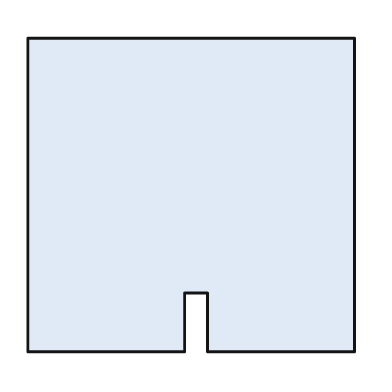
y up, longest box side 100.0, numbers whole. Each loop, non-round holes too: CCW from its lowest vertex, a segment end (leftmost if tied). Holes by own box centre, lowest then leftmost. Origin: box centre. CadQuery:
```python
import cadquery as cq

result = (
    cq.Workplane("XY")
    .moveTo(-50.0, -48.0)
    .lineTo(-2.0, -48.0)
    .lineTo(-2.0, -30.0)
    .lineTo(5.0, -30.0)
    .lineTo(5.0, -48.0)
    .lineTo(50.0, -48.0)
    .lineTo(50.0, 48.0)
    .lineTo(-50.0, 48.0)
    .close()
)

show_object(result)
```